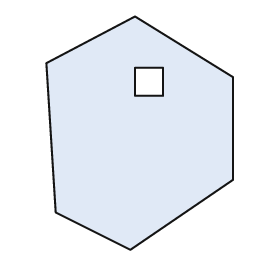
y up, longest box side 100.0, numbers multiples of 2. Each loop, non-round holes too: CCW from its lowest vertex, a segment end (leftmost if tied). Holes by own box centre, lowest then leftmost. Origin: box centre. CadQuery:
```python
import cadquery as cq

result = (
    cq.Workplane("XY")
    .moveTo(-4.0, -50.0)
    .lineTo(40.0, -20.0)
    .lineTo(40.0, 24.0)
    .lineTo(-2.0, 50.0)
    .lineTo(-40.0, 30.0)
    .lineTo(-36.0, -34.0)
    .close()
    .moveTo(-2.0, 16.0)
    .lineTo(10.0, 16.0)
    .lineTo(10.0, 28.0)
    .lineTo(-2.0, 28.0)
    .close()
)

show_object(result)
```